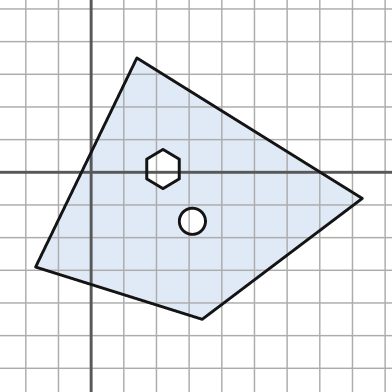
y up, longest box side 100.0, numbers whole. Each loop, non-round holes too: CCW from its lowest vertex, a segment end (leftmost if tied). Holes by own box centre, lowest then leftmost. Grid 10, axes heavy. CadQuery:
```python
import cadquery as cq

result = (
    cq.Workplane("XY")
    .moveTo(34.0, -45.0)
    .lineTo(83.0, -8.0)
    .lineTo(14.0, 35.0)
    .lineTo(-17.0, -29.0)
    .close()
    .moveTo(31.0, -15.0)
    .circle(4.0)
    .moveTo(22.0, -5.0)
    .lineTo(27.0, -2.0)
    .lineTo(27.0, 4.0)
    .lineTo(22.0, 7.0)
    .lineTo(17.0, 4.0)
    .lineTo(17.0, -2.0)
    .close()
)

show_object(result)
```